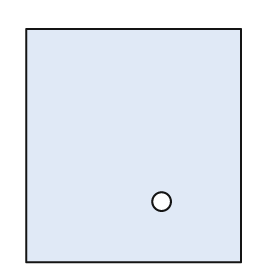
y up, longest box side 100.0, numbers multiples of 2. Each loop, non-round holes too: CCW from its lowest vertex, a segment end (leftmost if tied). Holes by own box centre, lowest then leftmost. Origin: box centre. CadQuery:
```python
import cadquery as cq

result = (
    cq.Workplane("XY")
    .moveTo(-46.0, -50.0)
    .lineTo(46.0, -50.0)
    .lineTo(46.0, 50.0)
    .lineTo(-46.0, 50.0)
    .close()
    .moveTo(12.0, -24.0)
    .circle(4.0)
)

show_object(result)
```